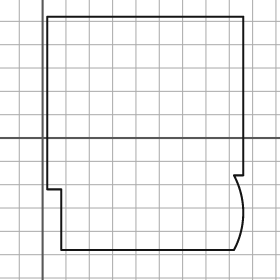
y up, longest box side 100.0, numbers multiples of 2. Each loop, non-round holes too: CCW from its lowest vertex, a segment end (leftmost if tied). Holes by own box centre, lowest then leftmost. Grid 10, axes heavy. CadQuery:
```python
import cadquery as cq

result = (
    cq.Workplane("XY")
    .moveTo(8.0, -48.0)
    .lineTo(82.0, -48.0)
    .threePointArc((86.0, -32.0), (82.0, -16.0))
    .lineTo(86.0, -16.0)
    .lineTo(86.0, 52.0)
    .lineTo(2.0, 52.0)
    .lineTo(2.0, -22.0)
    .lineTo(8.0, -22.0)
    .close()
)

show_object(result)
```